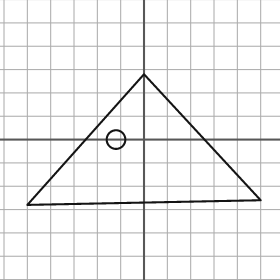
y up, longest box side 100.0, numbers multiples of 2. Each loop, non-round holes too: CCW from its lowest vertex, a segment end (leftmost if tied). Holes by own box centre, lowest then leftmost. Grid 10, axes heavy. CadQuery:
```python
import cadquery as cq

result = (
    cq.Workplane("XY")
    .moveTo(-50.0, -28.0)
    .lineTo(50.0, -26.0)
    .lineTo(0.0, 28.0)
    .close()
    .moveTo(-12.0, 0.0)
    .circle(4.0)
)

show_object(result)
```